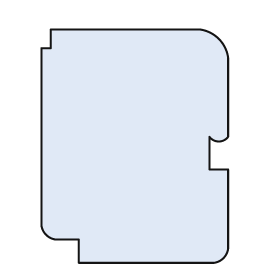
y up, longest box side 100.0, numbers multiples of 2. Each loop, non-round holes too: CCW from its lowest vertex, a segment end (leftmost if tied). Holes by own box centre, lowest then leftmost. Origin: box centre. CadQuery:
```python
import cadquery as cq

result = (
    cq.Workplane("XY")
    .moveTo(-24.0, -50.0)
    .lineTo(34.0, -50.0)
    .threePointArc((38.0, -48.0), (40.0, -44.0))
    .lineTo(40.0, -10.0)
    .lineTo(32.0, -10.0)
    .lineTo(32.0, 4.0)
    .threePointArc((36.0, 2.0), (40.0, 4.0))
    .lineTo(40.0, 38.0)
    .threePointArc((36.0, 46.0), (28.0, 50.0))
    .lineTo(-36.0, 50.0)
    .lineTo(-36.0, 42.0)
    .lineTo(-40.0, 42.0)
    .lineTo(-40.0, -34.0)
    .threePointArc((-38.0, -38.0), (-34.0, -40.0))
    .lineTo(-24.0, -40.0)
    .close()
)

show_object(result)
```